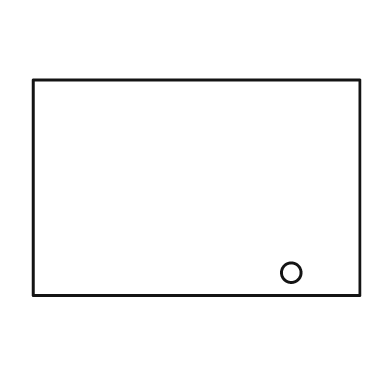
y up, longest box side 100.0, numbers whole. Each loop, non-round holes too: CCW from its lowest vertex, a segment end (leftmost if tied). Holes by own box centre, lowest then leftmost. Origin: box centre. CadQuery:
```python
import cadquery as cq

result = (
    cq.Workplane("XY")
    .moveTo(-50.0, -33.0)
    .lineTo(50.0, -33.0)
    .lineTo(50.0, 33.0)
    .lineTo(-50.0, 33.0)
    .close()
    .moveTo(29.0, -26.0)
    .circle(3.0)
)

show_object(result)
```